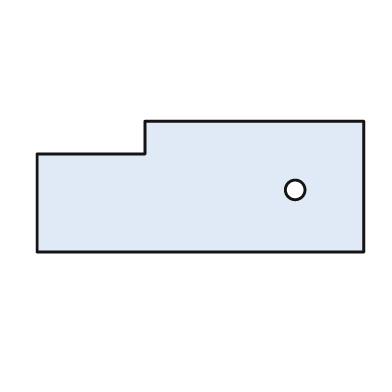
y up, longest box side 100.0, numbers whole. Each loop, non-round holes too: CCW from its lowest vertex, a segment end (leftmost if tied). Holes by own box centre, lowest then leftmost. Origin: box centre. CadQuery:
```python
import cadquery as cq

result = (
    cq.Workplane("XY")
    .moveTo(-50.0, -20.0)
    .lineTo(50.0, -20.0)
    .lineTo(50.0, 20.0)
    .lineTo(-17.0, 20.0)
    .lineTo(-17.0, 10.0)
    .lineTo(-50.0, 10.0)
    .close()
    .moveTo(29.0, -1.0)
    .circle(3.0)
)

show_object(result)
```